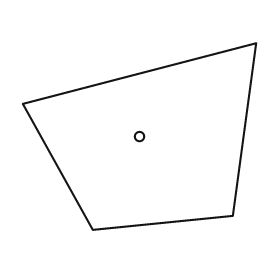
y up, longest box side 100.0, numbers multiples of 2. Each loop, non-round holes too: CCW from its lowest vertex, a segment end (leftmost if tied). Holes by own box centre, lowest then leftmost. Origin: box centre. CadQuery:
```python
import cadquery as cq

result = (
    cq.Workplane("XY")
    .moveTo(-20.0, -40.0)
    .lineTo(40.0, -34.0)
    .lineTo(50.0, 40.0)
    .lineTo(-50.0, 14.0)
    .close()
    .moveTo(0.0, 0.0)
    .circle(2.0)
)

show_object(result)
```